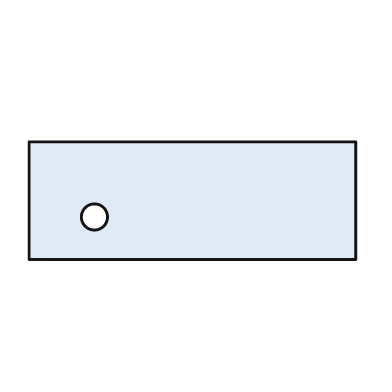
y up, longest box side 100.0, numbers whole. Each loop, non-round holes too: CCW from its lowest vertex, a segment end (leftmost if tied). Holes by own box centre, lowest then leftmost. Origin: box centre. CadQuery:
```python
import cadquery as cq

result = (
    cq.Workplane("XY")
    .moveTo(-50.0, -18.0)
    .lineTo(50.0, -18.0)
    .lineTo(50.0, 18.0)
    .lineTo(-50.0, 18.0)
    .close()
    .moveTo(-30.0, -5.0)
    .circle(4.0)
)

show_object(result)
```